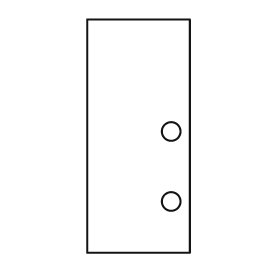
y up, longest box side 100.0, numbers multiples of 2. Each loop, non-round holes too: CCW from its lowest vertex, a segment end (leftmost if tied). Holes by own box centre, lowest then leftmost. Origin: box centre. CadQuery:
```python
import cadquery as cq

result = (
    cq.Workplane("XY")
    .moveTo(-22.0, -50.0)
    .lineTo(22.0, -50.0)
    .lineTo(22.0, 50.0)
    .lineTo(-22.0, 50.0)
    .close()
    .moveTo(14.0, -28.0)
    .circle(4.0)
    .moveTo(14.0, 2.0)
    .circle(4.0)
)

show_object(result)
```